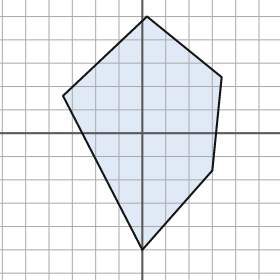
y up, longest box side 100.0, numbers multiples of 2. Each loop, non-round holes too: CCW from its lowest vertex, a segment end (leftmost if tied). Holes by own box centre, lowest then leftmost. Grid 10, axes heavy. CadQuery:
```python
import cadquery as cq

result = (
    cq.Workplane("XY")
    .moveTo(0.0, -50.0)
    .lineTo(30.0, -16.0)
    .lineTo(34.0, 24.0)
    .lineTo(2.0, 50.0)
    .lineTo(-34.0, 16.0)
    .close()
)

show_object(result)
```